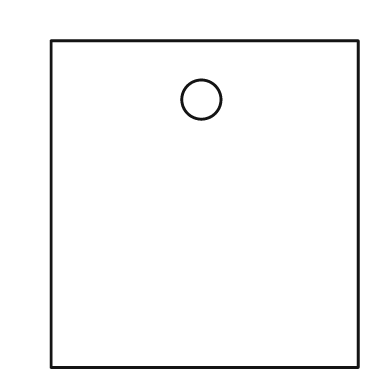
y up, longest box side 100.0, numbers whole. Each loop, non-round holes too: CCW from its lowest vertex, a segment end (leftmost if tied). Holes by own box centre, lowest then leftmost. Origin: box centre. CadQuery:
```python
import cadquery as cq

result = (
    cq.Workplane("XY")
    .moveTo(-47.0, -50.0)
    .lineTo(47.0, -50.0)
    .lineTo(47.0, 50.0)
    .lineTo(-47.0, 50.0)
    .close()
    .moveTo(-1.0, 32.0)
    .circle(6.0)
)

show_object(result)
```